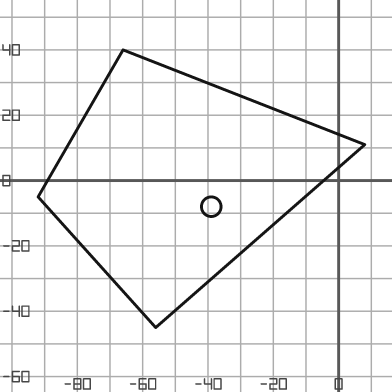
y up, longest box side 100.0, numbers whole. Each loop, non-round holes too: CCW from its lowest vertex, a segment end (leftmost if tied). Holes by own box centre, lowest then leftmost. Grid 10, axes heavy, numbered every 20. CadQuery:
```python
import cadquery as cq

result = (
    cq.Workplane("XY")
    .moveTo(-56.0, -45.0)
    .lineTo(8.0, 11.0)
    .lineTo(-66.0, 40.0)
    .lineTo(-92.0, -5.0)
    .close()
    .moveTo(-39.0, -8.0)
    .circle(3.0)
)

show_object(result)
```